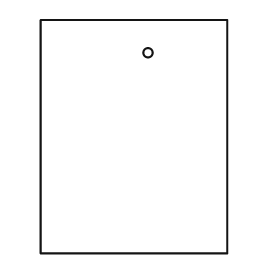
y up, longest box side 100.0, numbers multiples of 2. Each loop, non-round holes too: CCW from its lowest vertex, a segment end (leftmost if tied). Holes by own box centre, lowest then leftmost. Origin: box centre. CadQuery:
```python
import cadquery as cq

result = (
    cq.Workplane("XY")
    .moveTo(-40.0, -50.0)
    .lineTo(40.0, -50.0)
    .lineTo(40.0, 50.0)
    .lineTo(-40.0, 50.0)
    .close()
    .moveTo(6.0, 36.0)
    .circle(2.0)
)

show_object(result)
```